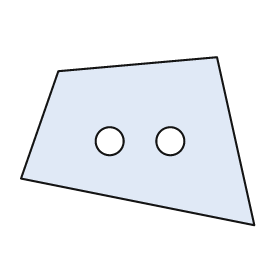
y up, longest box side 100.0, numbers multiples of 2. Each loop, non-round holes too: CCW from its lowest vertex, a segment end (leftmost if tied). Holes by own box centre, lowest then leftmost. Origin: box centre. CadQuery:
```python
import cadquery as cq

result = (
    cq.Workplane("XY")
    .moveTo(50.0, -36.0)
    .lineTo(34.0, 36.0)
    .lineTo(-34.0, 30.0)
    .lineTo(-50.0, -16.0)
    .close()
    .moveTo(-12.0, 0.0)
    .circle(6.0)
    .moveTo(14.0, 0.0)
    .circle(6.0)
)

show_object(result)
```